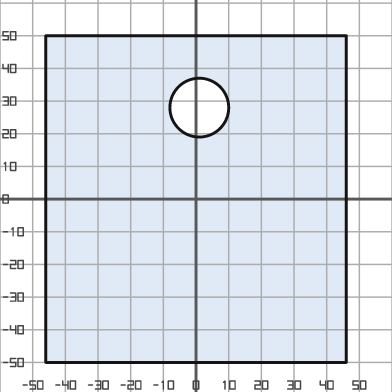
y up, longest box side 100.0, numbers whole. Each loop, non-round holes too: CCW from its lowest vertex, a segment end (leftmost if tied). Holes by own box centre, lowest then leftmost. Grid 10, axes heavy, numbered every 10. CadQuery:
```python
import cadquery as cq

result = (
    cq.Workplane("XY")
    .moveTo(-46.0, -50.0)
    .lineTo(46.0, -50.0)
    .lineTo(46.0, 50.0)
    .lineTo(-46.0, 50.0)
    .close()
    .moveTo(1.0, 28.0)
    .circle(9.0)
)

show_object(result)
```